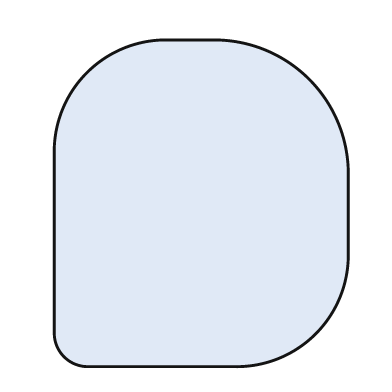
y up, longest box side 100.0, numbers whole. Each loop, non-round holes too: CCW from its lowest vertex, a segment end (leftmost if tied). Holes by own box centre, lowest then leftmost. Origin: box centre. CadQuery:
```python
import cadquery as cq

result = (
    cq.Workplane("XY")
    .moveTo(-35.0, -50.0)
    .lineTo(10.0, -50.0)
    .threePointArc((35.0, -40.0), (45.0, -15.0))
    .lineTo(45.0, 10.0)
    .threePointArc((33.0, 38.0), (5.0, 50.0))
    .lineTo(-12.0, 50.0)
    .threePointArc((-35.0, 40.0), (-45.0, 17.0))
    .lineTo(-45.0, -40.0)
    .threePointArc((-42.0, -47.0), (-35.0, -50.0))
    .close()
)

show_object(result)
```